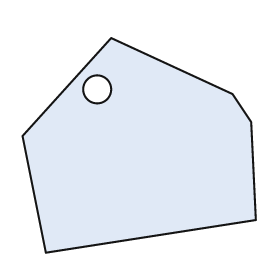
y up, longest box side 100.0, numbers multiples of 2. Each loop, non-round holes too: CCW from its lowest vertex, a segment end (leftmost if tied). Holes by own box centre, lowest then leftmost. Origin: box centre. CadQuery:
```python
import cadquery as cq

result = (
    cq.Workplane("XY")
    .moveTo(-40.0, -46.0)
    .lineTo(50.0, -32.0)
    .lineTo(48.0, 10.0)
    .lineTo(40.0, 22.0)
    .lineTo(-12.0, 46.0)
    .lineTo(-50.0, 4.0)
    .close()
    .moveTo(-18.0, 24.0)
    .circle(6.0)
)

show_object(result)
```